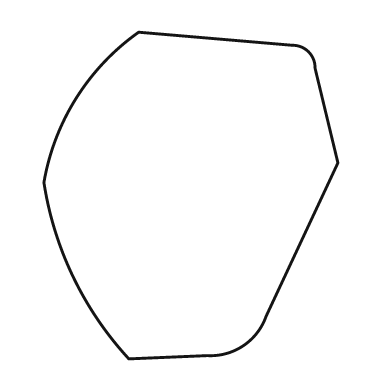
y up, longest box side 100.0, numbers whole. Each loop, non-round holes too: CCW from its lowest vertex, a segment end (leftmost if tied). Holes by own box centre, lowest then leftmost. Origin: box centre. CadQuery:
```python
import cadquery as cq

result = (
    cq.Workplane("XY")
    .moveTo(-19.0, -50.0)
    .lineTo(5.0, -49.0)
    .threePointArc((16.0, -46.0), (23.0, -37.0))
    .lineTo(45.0, 10.0)
    .lineTo(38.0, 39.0)
    .threePointArc((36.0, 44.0), (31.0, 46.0))
    .lineTo(-16.0, 50.0)
    .threePointArc((-35.0, 30.0), (-45.0, 4.0))
    .threePointArc((-36.0, -25.0), (-19.0, -50.0))
    .close()
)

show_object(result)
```